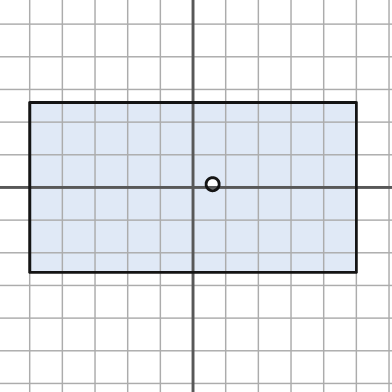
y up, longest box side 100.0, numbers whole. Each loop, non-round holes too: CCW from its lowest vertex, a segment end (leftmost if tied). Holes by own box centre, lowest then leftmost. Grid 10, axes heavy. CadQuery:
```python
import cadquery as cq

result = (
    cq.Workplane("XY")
    .moveTo(-50.0, -26.0)
    .lineTo(50.0, -26.0)
    .lineTo(50.0, 26.0)
    .lineTo(-50.0, 26.0)
    .close()
    .moveTo(6.0, 1.0)
    .circle(2.0)
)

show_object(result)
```